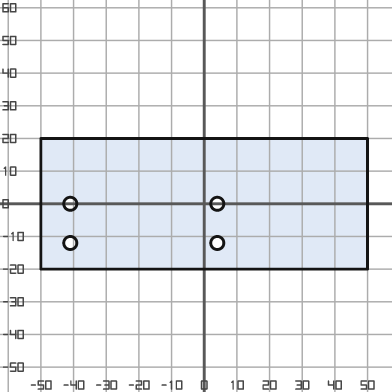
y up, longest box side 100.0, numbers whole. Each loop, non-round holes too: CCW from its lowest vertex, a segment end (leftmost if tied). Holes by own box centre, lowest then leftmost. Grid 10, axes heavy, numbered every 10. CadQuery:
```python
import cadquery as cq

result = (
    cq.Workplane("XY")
    .moveTo(-50.0, -20.0)
    .lineTo(50.0, -20.0)
    .lineTo(50.0, 20.0)
    .lineTo(-50.0, 20.0)
    .close()
    .moveTo(-41.0, -12.0)
    .circle(2.0)
    .moveTo(4.0, -12.0)
    .circle(2.0)
    .moveTo(-41.0, 0.0)
    .circle(2.0)
    .moveTo(4.0, 0.0)
    .circle(2.0)
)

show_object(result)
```